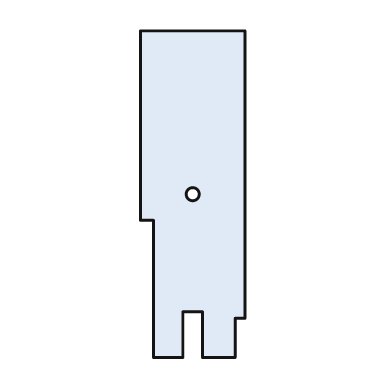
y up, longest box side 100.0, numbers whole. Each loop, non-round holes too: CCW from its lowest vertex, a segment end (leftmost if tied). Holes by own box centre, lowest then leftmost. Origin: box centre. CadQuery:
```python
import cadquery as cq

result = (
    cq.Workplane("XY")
    .moveTo(-12.0, -50.0)
    .lineTo(-3.0, -50.0)
    .lineTo(-3.0, -36.0)
    .lineTo(3.0, -36.0)
    .lineTo(3.0, -50.0)
    .lineTo(13.0, -50.0)
    .lineTo(13.0, -38.0)
    .lineTo(16.0, -38.0)
    .lineTo(16.0, 50.0)
    .lineTo(-16.0, 50.0)
    .lineTo(-16.0, -8.0)
    .lineTo(-12.0, -8.0)
    .close()
    .moveTo(0.0, 0.0)
    .circle(2.0)
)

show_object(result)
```